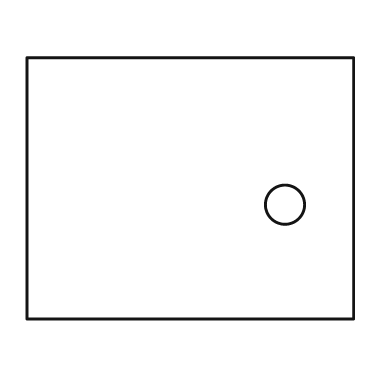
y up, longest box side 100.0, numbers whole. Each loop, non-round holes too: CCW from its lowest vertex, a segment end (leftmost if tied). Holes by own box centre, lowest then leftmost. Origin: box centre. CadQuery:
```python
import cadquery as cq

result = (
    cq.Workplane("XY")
    .moveTo(-50.0, -40.0)
    .lineTo(50.0, -40.0)
    .lineTo(50.0, 40.0)
    .lineTo(-50.0, 40.0)
    .close()
    .moveTo(29.0, -5.0)
    .circle(6.0)
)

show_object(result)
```